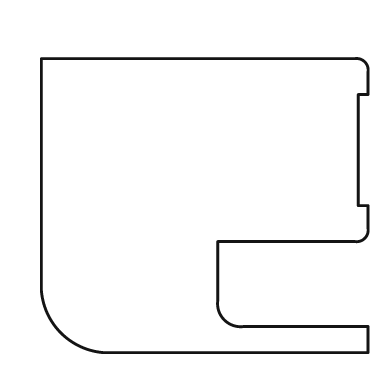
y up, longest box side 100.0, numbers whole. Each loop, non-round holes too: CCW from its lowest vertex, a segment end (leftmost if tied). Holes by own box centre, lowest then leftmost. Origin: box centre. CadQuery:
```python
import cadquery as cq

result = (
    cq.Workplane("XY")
    .moveTo(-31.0, -45.0)
    .lineTo(50.0, -45.0)
    .lineTo(50.0, -37.0)
    .lineTo(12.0, -37.0)
    .threePointArc((6.0, -35.0), (4.0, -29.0))
    .lineTo(4.0, -11.0)
    .lineTo(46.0, -11.0)
    .threePointArc((49.0, -10.0), (50.0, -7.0))
    .lineTo(50.0, 0.0)
    .lineTo(47.0, 0.0)
    .lineTo(47.0, 34.0)
    .lineTo(50.0, 34.0)
    .lineTo(50.0, 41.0)
    .threePointArc((49.0, 44.0), (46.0, 45.0))
    .lineTo(-50.0, 45.0)
    .lineTo(-50.0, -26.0)
    .threePointArc((-44.0, -39.0), (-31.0, -45.0))
    .close()
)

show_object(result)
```